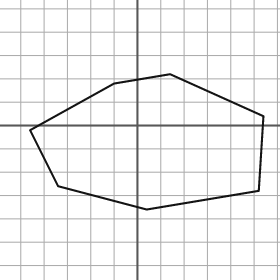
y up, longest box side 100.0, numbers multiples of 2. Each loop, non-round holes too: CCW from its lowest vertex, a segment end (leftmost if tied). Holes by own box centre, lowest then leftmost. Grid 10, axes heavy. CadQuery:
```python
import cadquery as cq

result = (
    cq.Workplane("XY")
    .moveTo(4.0, -36.0)
    .lineTo(52.0, -28.0)
    .lineTo(54.0, 4.0)
    .lineTo(14.0, 22.0)
    .lineTo(-10.0, 18.0)
    .lineTo(-46.0, -2.0)
    .lineTo(-34.0, -26.0)
    .close()
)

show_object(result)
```